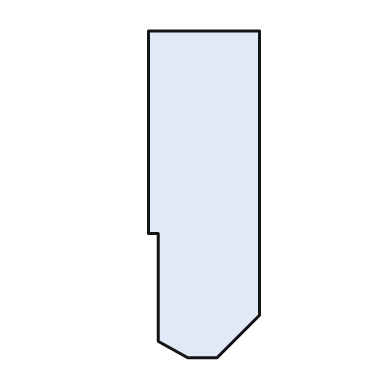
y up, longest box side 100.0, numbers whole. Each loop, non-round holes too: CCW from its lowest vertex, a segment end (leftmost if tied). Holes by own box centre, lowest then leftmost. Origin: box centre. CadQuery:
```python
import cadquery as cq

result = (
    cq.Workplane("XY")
    .moveTo(-5.0, -50.0)
    .lineTo(4.0, -50.0)
    .lineTo(17.0, -37.0)
    .lineTo(17.0, 50.0)
    .lineTo(-17.0, 50.0)
    .lineTo(-17.0, -12.0)
    .lineTo(-14.0, -12.0)
    .lineTo(-14.0, -45.0)
    .close()
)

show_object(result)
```